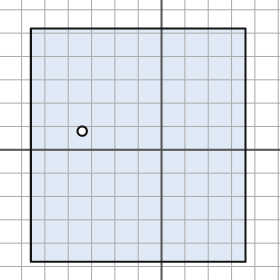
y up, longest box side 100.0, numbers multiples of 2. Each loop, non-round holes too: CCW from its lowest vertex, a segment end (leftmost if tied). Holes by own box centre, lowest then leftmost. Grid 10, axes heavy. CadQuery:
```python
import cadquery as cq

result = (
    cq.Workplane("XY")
    .moveTo(-56.0, -48.0)
    .lineTo(36.0, -48.0)
    .lineTo(36.0, 52.0)
    .lineTo(-56.0, 52.0)
    .close()
    .moveTo(-34.0, 8.0)
    .circle(2.0)
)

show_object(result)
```